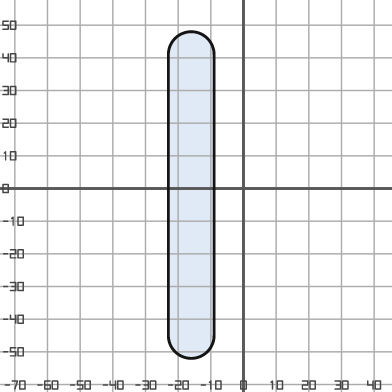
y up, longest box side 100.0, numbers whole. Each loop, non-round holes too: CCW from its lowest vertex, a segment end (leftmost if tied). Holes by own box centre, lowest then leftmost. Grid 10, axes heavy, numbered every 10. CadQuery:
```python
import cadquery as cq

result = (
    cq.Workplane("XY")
    .moveTo(-23.0, -45.0)
    .threePointArc((-16.0, -52.0), (-9.0, -45.0))
    .lineTo(-9.0, 41.0)
    .threePointArc((-16.0, 48.0), (-23.0, 41.0))
    .close()
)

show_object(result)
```